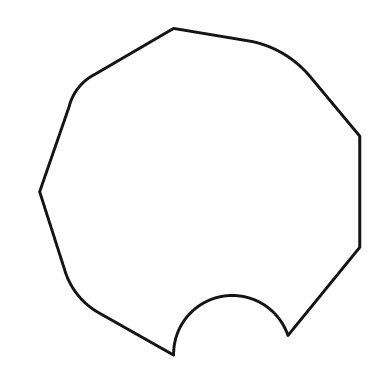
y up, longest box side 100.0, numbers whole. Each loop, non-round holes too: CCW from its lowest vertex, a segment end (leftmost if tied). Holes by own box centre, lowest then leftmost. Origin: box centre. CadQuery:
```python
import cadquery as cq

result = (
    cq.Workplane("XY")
    .moveTo(-8.0, -50.0)
    .threePointArc((7.0, -32.0), (27.0, -44.0))
    .lineTo(49.0, -17.0)
    .lineTo(49.0, 17.0)
    .lineTo(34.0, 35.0)
    .threePointArc((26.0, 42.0), (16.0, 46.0))
    .lineTo(-8.0, 50.0)
    .lineTo(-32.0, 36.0)
    .threePointArc((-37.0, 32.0), (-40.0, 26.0))
    .lineTo(-49.0, 0.0)
    .lineTo(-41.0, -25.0)
    .threePointArc((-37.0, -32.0), (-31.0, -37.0))
    .close()
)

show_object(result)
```